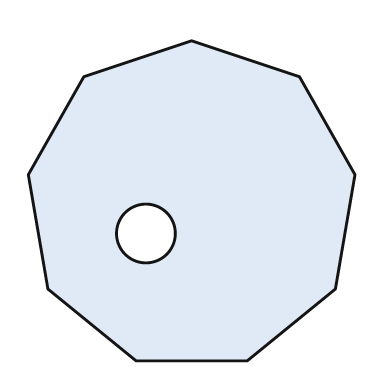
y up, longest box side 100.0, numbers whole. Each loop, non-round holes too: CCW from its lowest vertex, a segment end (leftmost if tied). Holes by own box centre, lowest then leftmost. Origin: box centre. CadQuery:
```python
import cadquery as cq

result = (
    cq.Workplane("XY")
    .moveTo(-17.0, -49.0)
    .lineTo(17.0, -49.0)
    .lineTo(44.0, -27.0)
    .lineTo(50.0, 8.0)
    .lineTo(33.0, 38.0)
    .lineTo(0.0, 49.0)
    .lineTo(-33.0, 38.0)
    .lineTo(-50.0, 8.0)
    .lineTo(-44.0, -27.0)
    .close()
    .moveTo(-14.0, -10.0)
    .circle(9.0)
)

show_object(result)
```